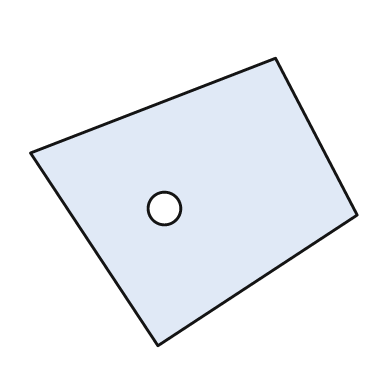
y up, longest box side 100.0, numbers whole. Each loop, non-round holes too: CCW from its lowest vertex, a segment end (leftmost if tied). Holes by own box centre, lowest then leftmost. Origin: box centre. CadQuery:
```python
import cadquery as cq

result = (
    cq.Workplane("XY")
    .moveTo(-11.0, -44.0)
    .lineTo(50.0, -4.0)
    .lineTo(25.0, 44.0)
    .lineTo(-50.0, 15.0)
    .close()
    .moveTo(-9.0, -2.0)
    .circle(5.0)
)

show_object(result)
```